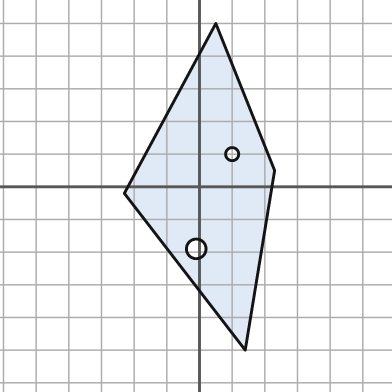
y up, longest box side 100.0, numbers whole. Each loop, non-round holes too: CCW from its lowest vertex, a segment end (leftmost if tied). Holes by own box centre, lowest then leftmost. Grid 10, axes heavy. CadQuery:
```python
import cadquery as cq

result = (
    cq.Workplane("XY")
    .moveTo(14.0, -50.0)
    .lineTo(23.0, 5.0)
    .lineTo(5.0, 50.0)
    .lineTo(-23.0, -2.0)
    .close()
    .moveTo(-1.0, -19.0)
    .circle(3.0)
    .moveTo(10.0, 10.0)
    .circle(2.0)
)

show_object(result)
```